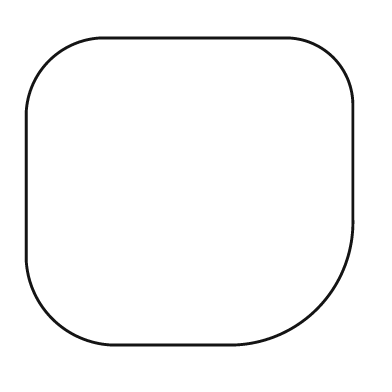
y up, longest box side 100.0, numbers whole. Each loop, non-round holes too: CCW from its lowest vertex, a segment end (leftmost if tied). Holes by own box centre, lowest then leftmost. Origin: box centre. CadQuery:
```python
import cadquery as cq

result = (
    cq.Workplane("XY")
    .moveTo(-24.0, -47.0)
    .lineTo(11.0, -47.0)
    .threePointArc((39.0, -36.0), (50.0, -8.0))
    .lineTo(50.0, 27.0)
    .threePointArc((44.0, 41.0), (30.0, 47.0))
    .lineTo(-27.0, 47.0)
    .threePointArc((-43.0, 40.0), (-50.0, 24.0))
    .lineTo(-50.0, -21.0)
    .threePointArc((-42.0, -39.0), (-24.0, -47.0))
    .close()
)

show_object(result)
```